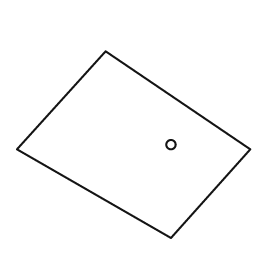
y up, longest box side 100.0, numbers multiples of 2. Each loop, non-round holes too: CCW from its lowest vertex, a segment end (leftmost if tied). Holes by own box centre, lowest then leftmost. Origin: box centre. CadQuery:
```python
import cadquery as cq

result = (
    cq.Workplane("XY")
    .moveTo(16.0, -40.0)
    .lineTo(50.0, -2.0)
    .lineTo(-12.0, 40.0)
    .lineTo(-50.0, -2.0)
    .close()
    .moveTo(16.0, 0.0)
    .circle(2.0)
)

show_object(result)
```